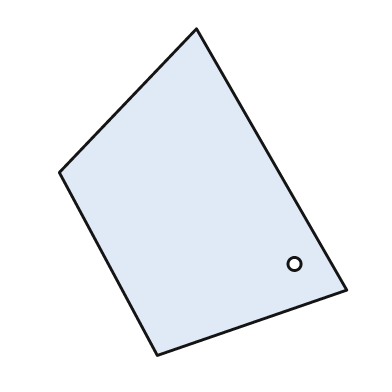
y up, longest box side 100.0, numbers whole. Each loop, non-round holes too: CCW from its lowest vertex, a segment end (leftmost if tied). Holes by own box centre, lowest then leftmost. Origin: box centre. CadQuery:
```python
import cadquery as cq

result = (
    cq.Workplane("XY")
    .moveTo(-14.0, -50.0)
    .lineTo(44.0, -30.0)
    .lineTo(-2.0, 50.0)
    .lineTo(-44.0, 6.0)
    .close()
    .moveTo(28.0, -22.0)
    .circle(2.0)
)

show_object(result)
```